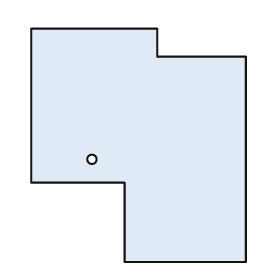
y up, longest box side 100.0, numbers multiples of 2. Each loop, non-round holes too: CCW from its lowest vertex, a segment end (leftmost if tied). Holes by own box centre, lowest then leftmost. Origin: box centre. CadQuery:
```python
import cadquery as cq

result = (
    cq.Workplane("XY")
    .moveTo(-6.0, -50.0)
    .lineTo(46.0, -50.0)
    .lineTo(46.0, 38.0)
    .lineTo(8.0, 38.0)
    .lineTo(8.0, 50.0)
    .lineTo(-46.0, 50.0)
    .lineTo(-46.0, -16.0)
    .lineTo(-6.0, -16.0)
    .close()
    .moveTo(-20.0, -6.0)
    .circle(2.0)
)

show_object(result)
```